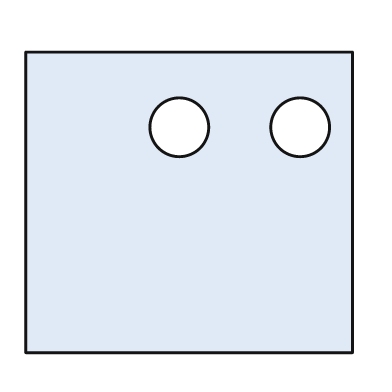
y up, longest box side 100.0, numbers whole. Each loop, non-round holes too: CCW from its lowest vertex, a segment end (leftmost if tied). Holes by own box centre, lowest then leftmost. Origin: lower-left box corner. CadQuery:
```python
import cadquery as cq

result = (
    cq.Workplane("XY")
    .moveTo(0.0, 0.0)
    .lineTo(100.0, 0.0)
    .lineTo(100.0, 92.0)
    .lineTo(0.0, 92.0)
    .close()
    .moveTo(47.0, 69.0)
    .circle(9.0)
    .moveTo(84.0, 69.0)
    .circle(9.0)
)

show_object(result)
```